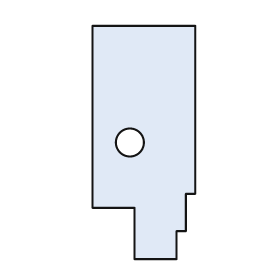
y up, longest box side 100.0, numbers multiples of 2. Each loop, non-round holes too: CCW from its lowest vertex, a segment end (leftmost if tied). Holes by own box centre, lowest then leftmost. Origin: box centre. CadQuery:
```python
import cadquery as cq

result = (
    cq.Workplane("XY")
    .moveTo(-4.0, -50.0)
    .lineTo(14.0, -50.0)
    .lineTo(14.0, -38.0)
    .lineTo(18.0, -38.0)
    .lineTo(18.0, -22.0)
    .lineTo(22.0, -22.0)
    .lineTo(22.0, 50.0)
    .lineTo(-22.0, 50.0)
    .lineTo(-22.0, -28.0)
    .lineTo(-4.0, -28.0)
    .close()
    .moveTo(-6.0, 0.0)
    .circle(6.0)
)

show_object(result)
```